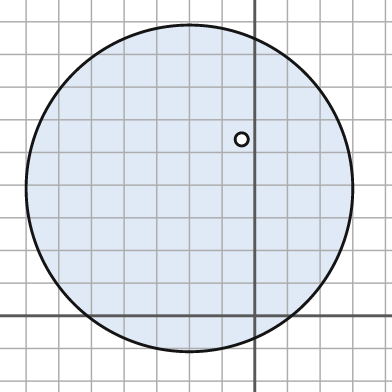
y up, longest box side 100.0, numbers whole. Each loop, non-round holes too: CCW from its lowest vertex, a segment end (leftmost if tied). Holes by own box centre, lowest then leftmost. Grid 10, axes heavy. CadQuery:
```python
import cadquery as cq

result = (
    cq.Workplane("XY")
    .moveTo(-20.0, 39.0)
    .circle(50.0)
    .moveTo(-4.0, 54.0)
    .circle(2.0)
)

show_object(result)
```